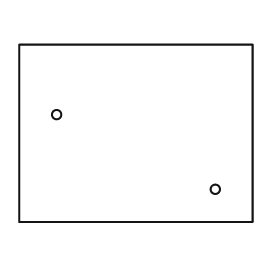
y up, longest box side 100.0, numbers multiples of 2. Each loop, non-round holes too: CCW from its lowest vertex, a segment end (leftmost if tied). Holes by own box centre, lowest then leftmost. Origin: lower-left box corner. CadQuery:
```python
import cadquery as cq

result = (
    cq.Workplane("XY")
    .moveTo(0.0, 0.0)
    .lineTo(100.0, 0.0)
    .lineTo(100.0, 76.0)
    .lineTo(0.0, 76.0)
    .close()
    .moveTo(84.0, 14.0)
    .circle(2.0)
    .moveTo(16.0, 46.0)
    .circle(2.0)
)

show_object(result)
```